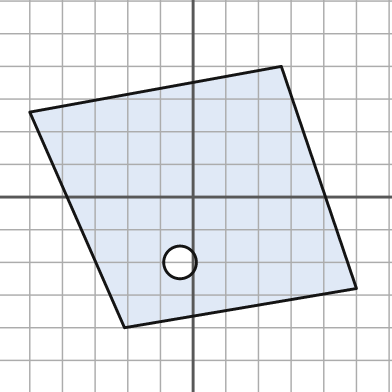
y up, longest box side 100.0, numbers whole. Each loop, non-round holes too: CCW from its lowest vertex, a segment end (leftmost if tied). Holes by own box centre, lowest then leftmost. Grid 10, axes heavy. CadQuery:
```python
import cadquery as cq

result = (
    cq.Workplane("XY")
    .moveTo(-21.0, -40.0)
    .lineTo(50.0, -28.0)
    .lineTo(27.0, 40.0)
    .lineTo(-50.0, 26.0)
    .close()
    .moveTo(-4.0, -20.0)
    .circle(5.0)
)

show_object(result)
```